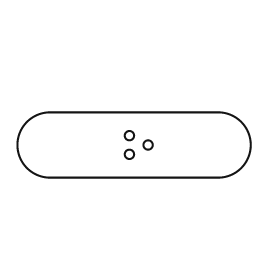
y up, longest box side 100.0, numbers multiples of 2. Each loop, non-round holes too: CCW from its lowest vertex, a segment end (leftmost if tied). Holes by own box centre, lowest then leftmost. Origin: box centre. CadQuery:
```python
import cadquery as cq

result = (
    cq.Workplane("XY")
    .moveTo(-36.0, -14.0)
    .lineTo(36.0, -14.0)
    .threePointArc((50.0, 0.0), (36.0, 14.0))
    .lineTo(-36.0, 14.0)
    .threePointArc((-50.0, 0.0), (-36.0, -14.0))
    .close()
    .moveTo(-2.0, -4.0)
    .circle(2.0)
    .moveTo(6.0, 0.0)
    .circle(2.0)
    .moveTo(-2.0, 4.0)
    .circle(2.0)
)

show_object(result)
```